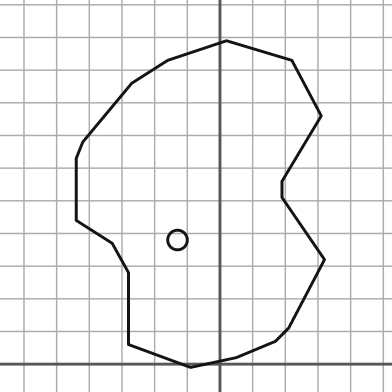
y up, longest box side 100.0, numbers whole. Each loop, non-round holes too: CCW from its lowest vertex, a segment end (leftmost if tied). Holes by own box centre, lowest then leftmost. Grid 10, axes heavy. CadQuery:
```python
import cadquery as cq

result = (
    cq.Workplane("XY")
    .moveTo(-9.0, -1.0)
    .lineTo(5.0, 2.0)
    .lineTo(17.0, 7.0)
    .lineTo(21.0, 11.0)
    .lineTo(32.0, 32.0)
    .lineTo(19.0, 51.0)
    .lineTo(19.0, 56.0)
    .lineTo(31.0, 76.0)
    .lineTo(22.0, 93.0)
    .lineTo(2.0, 99.0)
    .lineTo(-16.0, 93.0)
    .lineTo(-27.0, 86.0)
    .lineTo(-42.0, 68.0)
    .lineTo(-44.0, 63.0)
    .lineTo(-44.0, 44.0)
    .lineTo(-33.0, 37.0)
    .lineTo(-28.0, 28.0)
    .lineTo(-28.0, 6.0)
    .close()
    .moveTo(-13.0, 38.0)
    .circle(3.0)
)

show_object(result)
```